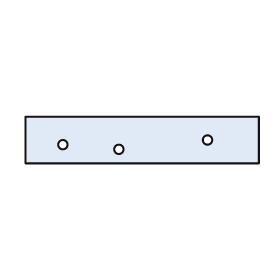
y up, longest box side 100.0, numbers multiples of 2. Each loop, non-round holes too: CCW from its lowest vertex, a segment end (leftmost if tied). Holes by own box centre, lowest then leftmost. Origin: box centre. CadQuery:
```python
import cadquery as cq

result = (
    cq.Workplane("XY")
    .moveTo(-50.0, -10.0)
    .lineTo(50.0, -10.0)
    .lineTo(50.0, 10.0)
    .lineTo(-50.0, 10.0)
    .close()
    .moveTo(-10.0, -4.0)
    .circle(2.0)
    .moveTo(-34.0, -2.0)
    .circle(2.0)
    .moveTo(28.0, 0.0)
    .circle(2.0)
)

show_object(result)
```